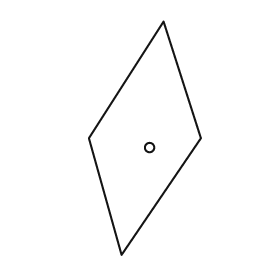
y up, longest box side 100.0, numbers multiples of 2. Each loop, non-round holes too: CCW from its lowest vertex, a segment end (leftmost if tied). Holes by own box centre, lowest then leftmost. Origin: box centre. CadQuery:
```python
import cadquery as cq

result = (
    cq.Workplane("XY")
    .moveTo(-10.0, -50.0)
    .lineTo(24.0, 0.0)
    .lineTo(8.0, 50.0)
    .lineTo(-24.0, 0.0)
    .close()
    .moveTo(2.0, -4.0)
    .circle(2.0)
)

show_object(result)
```